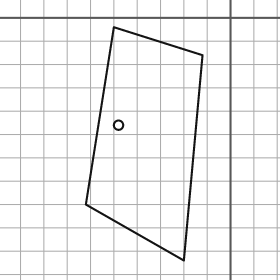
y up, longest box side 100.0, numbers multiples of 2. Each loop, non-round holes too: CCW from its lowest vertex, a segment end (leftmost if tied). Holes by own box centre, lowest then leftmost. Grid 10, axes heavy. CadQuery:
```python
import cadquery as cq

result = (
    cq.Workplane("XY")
    .moveTo(-20.0, -104.0)
    .lineTo(-12.0, -16.0)
    .lineTo(-50.0, -4.0)
    .lineTo(-62.0, -80.0)
    .close()
    .moveTo(-48.0, -46.0)
    .circle(2.0)
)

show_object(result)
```